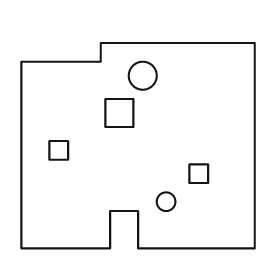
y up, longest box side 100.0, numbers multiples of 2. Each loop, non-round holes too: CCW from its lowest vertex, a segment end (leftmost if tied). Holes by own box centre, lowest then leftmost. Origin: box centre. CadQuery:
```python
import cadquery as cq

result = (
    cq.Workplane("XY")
    .moveTo(-50.0, -44.0)
    .lineTo(-12.0, -44.0)
    .lineTo(-12.0, -28.0)
    .lineTo(0.0, -28.0)
    .lineTo(0.0, -44.0)
    .lineTo(50.0, -44.0)
    .lineTo(50.0, 44.0)
    .lineTo(-16.0, 44.0)
    .lineTo(-16.0, 36.0)
    .lineTo(-50.0, 36.0)
    .close()
    .moveTo(12.0, -24.0)
    .circle(4.0)
    .moveTo(22.0, -16.0)
    .lineTo(30.0, -16.0)
    .lineTo(30.0, -8.0)
    .lineTo(22.0, -8.0)
    .close()
    .moveTo(-38.0, -6.0)
    .lineTo(-30.0, -6.0)
    .lineTo(-30.0, 2.0)
    .lineTo(-38.0, 2.0)
    .close()
    .moveTo(-14.0, 8.0)
    .lineTo(-2.0, 8.0)
    .lineTo(-2.0, 20.0)
    .lineTo(-14.0, 20.0)
    .close()
    .moveTo(2.0, 30.0)
    .circle(6.0)
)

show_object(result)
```